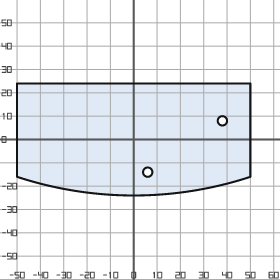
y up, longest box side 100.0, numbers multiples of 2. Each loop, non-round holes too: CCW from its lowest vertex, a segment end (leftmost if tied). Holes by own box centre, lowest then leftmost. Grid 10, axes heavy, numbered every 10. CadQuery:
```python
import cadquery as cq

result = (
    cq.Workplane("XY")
    .moveTo(-50.0, -16.0)
    .threePointArc((0.0, -24.0), (50.0, -16.0))
    .lineTo(50.0, 24.0)
    .lineTo(-50.0, 24.0)
    .close()
    .moveTo(6.0, -14.0)
    .circle(2.0)
    .moveTo(38.0, 8.0)
    .circle(2.0)
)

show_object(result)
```